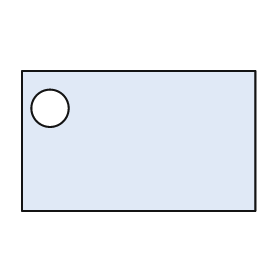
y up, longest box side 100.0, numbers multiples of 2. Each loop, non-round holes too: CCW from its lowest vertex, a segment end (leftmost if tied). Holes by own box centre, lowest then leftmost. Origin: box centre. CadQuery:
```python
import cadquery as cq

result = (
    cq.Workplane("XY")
    .moveTo(-50.0, -30.0)
    .lineTo(50.0, -30.0)
    .lineTo(50.0, 30.0)
    .lineTo(-50.0, 30.0)
    .close()
    .moveTo(-38.0, 14.0)
    .circle(8.0)
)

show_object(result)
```